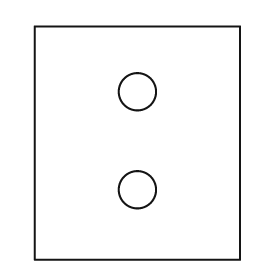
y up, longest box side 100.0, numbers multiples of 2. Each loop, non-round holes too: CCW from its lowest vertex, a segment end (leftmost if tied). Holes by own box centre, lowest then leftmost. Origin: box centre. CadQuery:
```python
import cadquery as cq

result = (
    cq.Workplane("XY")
    .moveTo(-44.0, -50.0)
    .lineTo(44.0, -50.0)
    .lineTo(44.0, 50.0)
    .lineTo(-44.0, 50.0)
    .close()
    .moveTo(0.0, -20.0)
    .circle(8.0)
    .moveTo(0.0, 22.0)
    .circle(8.0)
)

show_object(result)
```